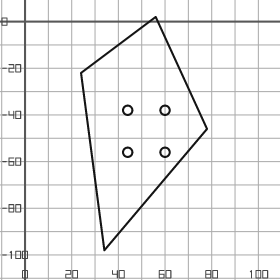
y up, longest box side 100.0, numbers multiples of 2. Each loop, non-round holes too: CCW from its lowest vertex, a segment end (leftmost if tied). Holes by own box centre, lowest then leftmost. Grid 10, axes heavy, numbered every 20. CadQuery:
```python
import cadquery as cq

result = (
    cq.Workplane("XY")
    .moveTo(34.0, -98.0)
    .lineTo(78.0, -46.0)
    .lineTo(56.0, 2.0)
    .lineTo(24.0, -22.0)
    .close()
    .moveTo(44.0, -56.0)
    .circle(2.0)
    .moveTo(60.0, -56.0)
    .circle(2.0)
    .moveTo(44.0, -38.0)
    .circle(2.0)
    .moveTo(60.0, -38.0)
    .circle(2.0)
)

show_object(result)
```